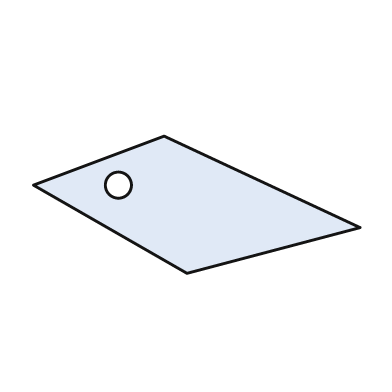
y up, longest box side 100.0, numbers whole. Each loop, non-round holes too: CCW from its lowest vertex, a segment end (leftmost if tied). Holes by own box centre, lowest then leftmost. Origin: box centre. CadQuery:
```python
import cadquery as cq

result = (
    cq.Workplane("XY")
    .moveTo(-3.0, -21.0)
    .lineTo(50.0, -7.0)
    .lineTo(-10.0, 21.0)
    .lineTo(-50.0, 6.0)
    .close()
    .moveTo(-24.0, 6.0)
    .circle(4.0)
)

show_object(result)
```